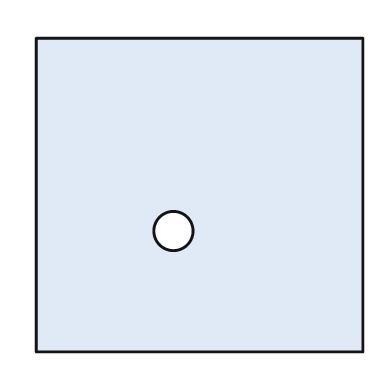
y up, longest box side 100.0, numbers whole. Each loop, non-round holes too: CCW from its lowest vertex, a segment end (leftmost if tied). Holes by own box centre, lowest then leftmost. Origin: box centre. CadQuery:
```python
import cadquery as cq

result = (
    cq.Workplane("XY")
    .moveTo(-50.0, -48.0)
    .lineTo(50.0, -48.0)
    .lineTo(50.0, 48.0)
    .lineTo(-50.0, 48.0)
    .close()
    .moveTo(-8.0, -11.0)
    .circle(6.0)
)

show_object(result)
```